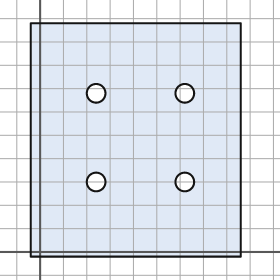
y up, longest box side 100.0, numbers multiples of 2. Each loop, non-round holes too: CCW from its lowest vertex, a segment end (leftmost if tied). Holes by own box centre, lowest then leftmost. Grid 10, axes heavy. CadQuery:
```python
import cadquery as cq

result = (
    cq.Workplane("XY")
    .moveTo(-4.0, -2.0)
    .lineTo(86.0, -2.0)
    .lineTo(86.0, 98.0)
    .lineTo(-4.0, 98.0)
    .close()
    .moveTo(24.0, 30.0)
    .circle(4.0)
    .moveTo(62.0, 30.0)
    .circle(4.0)
    .moveTo(24.0, 68.0)
    .circle(4.0)
    .moveTo(62.0, 68.0)
    .circle(4.0)
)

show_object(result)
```